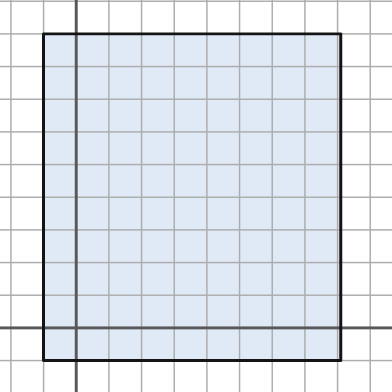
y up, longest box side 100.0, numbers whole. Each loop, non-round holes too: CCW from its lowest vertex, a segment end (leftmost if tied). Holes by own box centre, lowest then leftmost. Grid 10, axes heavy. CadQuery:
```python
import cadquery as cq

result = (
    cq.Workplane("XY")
    .moveTo(-10.0, -10.0)
    .lineTo(81.0, -10.0)
    .lineTo(81.0, 90.0)
    .lineTo(-10.0, 90.0)
    .close()
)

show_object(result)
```